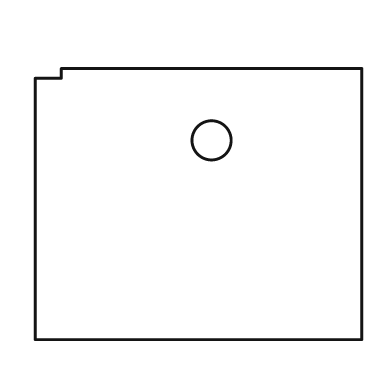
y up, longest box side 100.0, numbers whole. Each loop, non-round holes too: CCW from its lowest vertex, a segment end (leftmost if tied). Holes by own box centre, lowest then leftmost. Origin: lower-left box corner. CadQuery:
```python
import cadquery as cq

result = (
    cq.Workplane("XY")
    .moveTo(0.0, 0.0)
    .lineTo(100.0, 0.0)
    .lineTo(100.0, 83.0)
    .lineTo(8.0, 83.0)
    .lineTo(8.0, 80.0)
    .lineTo(0.0, 80.0)
    .close()
    .moveTo(54.0, 61.0)
    .circle(6.0)
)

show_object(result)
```